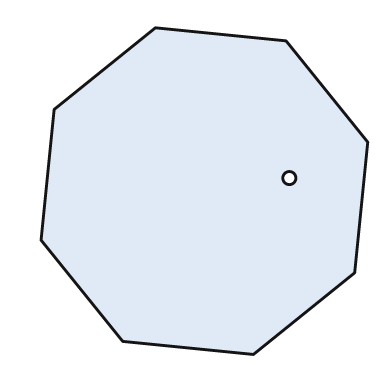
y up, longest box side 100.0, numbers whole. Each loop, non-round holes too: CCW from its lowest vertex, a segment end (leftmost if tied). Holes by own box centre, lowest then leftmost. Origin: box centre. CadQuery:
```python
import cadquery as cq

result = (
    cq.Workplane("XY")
    .moveTo(15.0, -50.0)
    .lineTo(46.0, -25.0)
    .lineTo(50.0, 15.0)
    .lineTo(25.0, 46.0)
    .lineTo(-15.0, 50.0)
    .lineTo(-46.0, 25.0)
    .lineTo(-50.0, -15.0)
    .lineTo(-25.0, -46.0)
    .close()
    .moveTo(26.0, 4.0)
    .circle(2.0)
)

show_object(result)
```